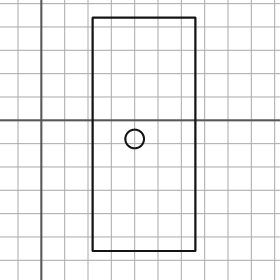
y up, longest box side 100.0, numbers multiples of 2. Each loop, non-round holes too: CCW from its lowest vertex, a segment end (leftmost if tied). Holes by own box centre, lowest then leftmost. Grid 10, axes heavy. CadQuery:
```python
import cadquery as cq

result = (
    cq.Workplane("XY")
    .moveTo(22.0, -56.0)
    .lineTo(66.0, -56.0)
    .lineTo(66.0, 44.0)
    .lineTo(22.0, 44.0)
    .close()
    .moveTo(40.0, -8.0)
    .circle(4.0)
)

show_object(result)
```